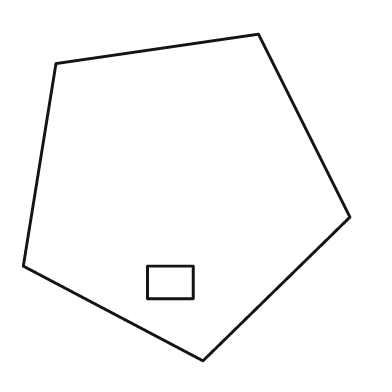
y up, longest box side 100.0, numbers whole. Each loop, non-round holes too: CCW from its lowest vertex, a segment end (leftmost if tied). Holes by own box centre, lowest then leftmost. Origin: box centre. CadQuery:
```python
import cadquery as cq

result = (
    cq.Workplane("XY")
    .moveTo(5.0, -50.0)
    .lineTo(50.0, -6.0)
    .lineTo(22.0, 50.0)
    .lineTo(-40.0, 41.0)
    .lineTo(-50.0, -21.0)
    .close()
    .moveTo(-12.0, -31.0)
    .lineTo(2.0, -31.0)
    .lineTo(2.0, -21.0)
    .lineTo(-12.0, -21.0)
    .close()
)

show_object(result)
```